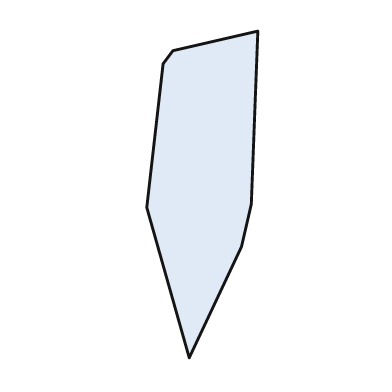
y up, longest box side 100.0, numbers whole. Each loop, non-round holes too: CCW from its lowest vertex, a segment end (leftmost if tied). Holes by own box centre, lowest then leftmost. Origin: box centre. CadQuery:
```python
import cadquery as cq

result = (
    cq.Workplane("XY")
    .moveTo(-4.0, -50.0)
    .lineTo(12.0, -16.0)
    .lineTo(15.0, -3.0)
    .lineTo(17.0, 50.0)
    .lineTo(-9.0, 44.0)
    .lineTo(-12.0, 40.0)
    .lineTo(-17.0, -4.0)
    .close()
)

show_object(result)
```